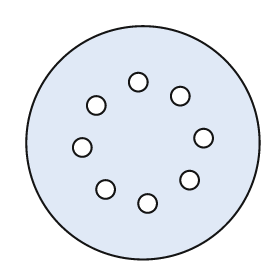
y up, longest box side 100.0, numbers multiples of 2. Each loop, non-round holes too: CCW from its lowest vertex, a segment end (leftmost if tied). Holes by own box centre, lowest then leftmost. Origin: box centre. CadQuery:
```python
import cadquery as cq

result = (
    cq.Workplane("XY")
    .moveTo(0.0, 0.0)
    .circle(50.0)
    .moveTo(2.0, -26.0)
    .circle(4.0)
    .moveTo(-16.0, -20.0)
    .circle(4.0)
    .moveTo(20.0, -16.0)
    .circle(4.0)
    .moveTo(-26.0, -2.0)
    .circle(4.0)
    .moveTo(26.0, 2.0)
    .circle(4.0)
    .moveTo(-20.0, 16.0)
    .circle(4.0)
    .moveTo(16.0, 20.0)
    .circle(4.0)
    .moveTo(-2.0, 26.0)
    .circle(4.0)
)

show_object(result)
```